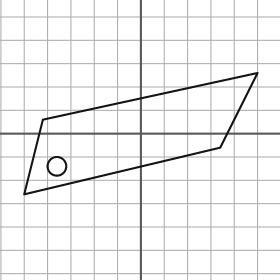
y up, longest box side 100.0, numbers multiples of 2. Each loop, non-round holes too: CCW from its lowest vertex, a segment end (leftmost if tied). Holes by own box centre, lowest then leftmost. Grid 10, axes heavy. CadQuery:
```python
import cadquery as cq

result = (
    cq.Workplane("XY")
    .moveTo(-50.0, -26.0)
    .lineTo(34.0, -6.0)
    .lineTo(50.0, 26.0)
    .lineTo(-42.0, 6.0)
    .close()
    .moveTo(-36.0, -14.0)
    .circle(4.0)
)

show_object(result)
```